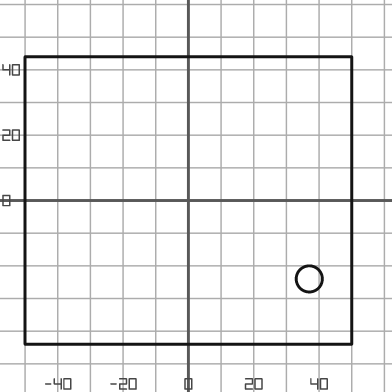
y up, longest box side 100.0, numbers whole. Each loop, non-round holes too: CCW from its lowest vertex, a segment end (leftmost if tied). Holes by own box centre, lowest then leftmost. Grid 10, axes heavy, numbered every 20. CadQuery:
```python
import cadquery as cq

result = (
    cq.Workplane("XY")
    .moveTo(-50.0, -44.0)
    .lineTo(50.0, -44.0)
    .lineTo(50.0, 44.0)
    .lineTo(-50.0, 44.0)
    .close()
    .moveTo(37.0, -24.0)
    .circle(4.0)
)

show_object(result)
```